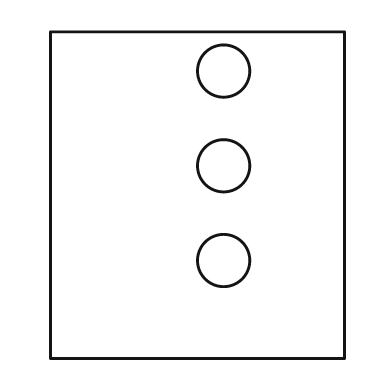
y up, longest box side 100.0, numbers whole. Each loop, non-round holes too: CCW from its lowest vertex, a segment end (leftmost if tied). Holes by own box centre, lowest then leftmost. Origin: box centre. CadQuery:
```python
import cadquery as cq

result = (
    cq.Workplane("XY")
    .moveTo(-45.0, -50.0)
    .lineTo(45.0, -50.0)
    .lineTo(45.0, 50.0)
    .lineTo(-45.0, 50.0)
    .close()
    .moveTo(8.0, -20.0)
    .circle(8.0)
    .moveTo(8.0, 9.0)
    .circle(8.0)
    .moveTo(8.0, 38.0)
    .circle(8.0)
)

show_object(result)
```